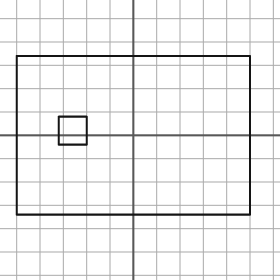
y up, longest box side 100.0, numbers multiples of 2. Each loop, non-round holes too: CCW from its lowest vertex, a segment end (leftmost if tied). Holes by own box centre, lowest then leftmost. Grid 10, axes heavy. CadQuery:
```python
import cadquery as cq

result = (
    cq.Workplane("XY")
    .moveTo(-50.0, -34.0)
    .lineTo(50.0, -34.0)
    .lineTo(50.0, 34.0)
    .lineTo(-50.0, 34.0)
    .close()
    .moveTo(-32.0, -4.0)
    .lineTo(-20.0, -4.0)
    .lineTo(-20.0, 8.0)
    .lineTo(-32.0, 8.0)
    .close()
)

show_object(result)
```